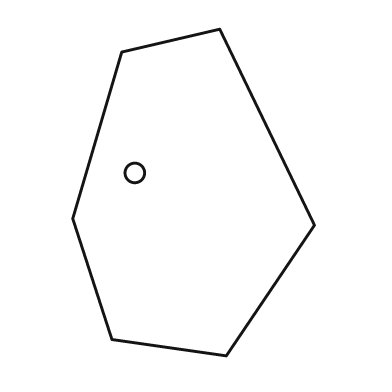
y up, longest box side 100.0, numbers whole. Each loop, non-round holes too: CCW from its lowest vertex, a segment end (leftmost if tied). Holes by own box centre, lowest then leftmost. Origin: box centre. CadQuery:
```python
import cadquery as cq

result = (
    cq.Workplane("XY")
    .moveTo(10.0, -50.0)
    .lineTo(37.0, -10.0)
    .lineTo(8.0, 50.0)
    .lineTo(-22.0, 43.0)
    .lineTo(-37.0, -8.0)
    .lineTo(-25.0, -45.0)
    .close()
    .moveTo(-18.0, 6.0)
    .circle(3.0)
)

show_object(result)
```